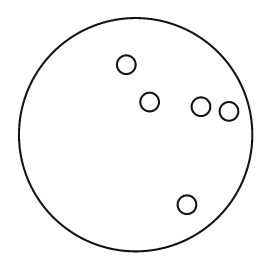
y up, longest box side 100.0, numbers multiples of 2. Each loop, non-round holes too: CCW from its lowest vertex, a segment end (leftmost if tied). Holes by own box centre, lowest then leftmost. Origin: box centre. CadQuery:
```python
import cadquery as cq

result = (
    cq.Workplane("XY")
    .moveTo(0.0, 0.0)
    .circle(50.0)
    .moveTo(22.0, -30.0)
    .circle(4.0)
    .moveTo(40.0, 10.0)
    .circle(4.0)
    .moveTo(28.0, 12.0)
    .circle(4.0)
    .moveTo(6.0, 14.0)
    .circle(4.0)
    .moveTo(-4.0, 30.0)
    .circle(4.0)
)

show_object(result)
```